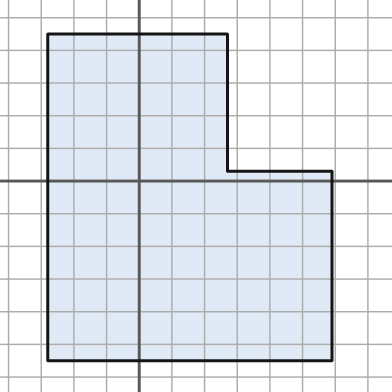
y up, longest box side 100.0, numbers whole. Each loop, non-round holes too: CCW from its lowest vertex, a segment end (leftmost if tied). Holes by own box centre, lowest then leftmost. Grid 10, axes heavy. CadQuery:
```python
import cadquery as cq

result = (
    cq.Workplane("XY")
    .moveTo(-28.0, -55.0)
    .lineTo(59.0, -55.0)
    .lineTo(59.0, 3.0)
    .lineTo(27.0, 3.0)
    .lineTo(27.0, 45.0)
    .lineTo(-28.0, 45.0)
    .close()
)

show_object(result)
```